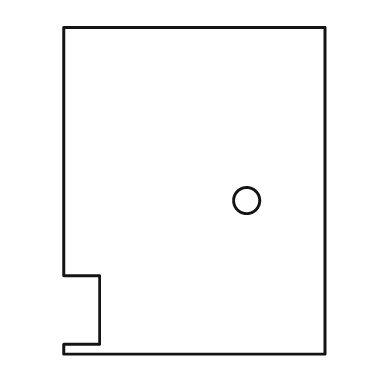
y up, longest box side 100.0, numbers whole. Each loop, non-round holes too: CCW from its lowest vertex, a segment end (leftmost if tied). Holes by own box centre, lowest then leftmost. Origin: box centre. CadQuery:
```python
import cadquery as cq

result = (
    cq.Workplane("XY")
    .moveTo(-40.0, -50.0)
    .lineTo(40.0, -50.0)
    .lineTo(40.0, 50.0)
    .lineTo(-40.0, 50.0)
    .lineTo(-40.0, -26.0)
    .lineTo(-29.0, -26.0)
    .lineTo(-29.0, -47.0)
    .lineTo(-40.0, -47.0)
    .close()
    .moveTo(16.0, -3.0)
    .circle(4.0)
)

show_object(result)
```